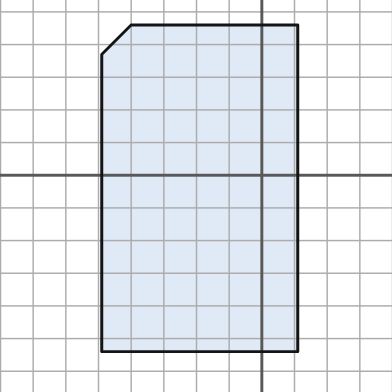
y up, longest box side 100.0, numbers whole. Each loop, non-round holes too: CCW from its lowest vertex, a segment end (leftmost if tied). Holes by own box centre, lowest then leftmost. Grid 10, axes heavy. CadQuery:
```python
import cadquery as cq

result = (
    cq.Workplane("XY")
    .moveTo(-49.0, -54.0)
    .lineTo(11.0, -54.0)
    .lineTo(11.0, 46.0)
    .lineTo(-40.0, 46.0)
    .lineTo(-49.0, 37.0)
    .close()
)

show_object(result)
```